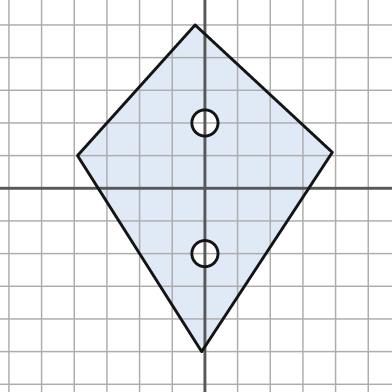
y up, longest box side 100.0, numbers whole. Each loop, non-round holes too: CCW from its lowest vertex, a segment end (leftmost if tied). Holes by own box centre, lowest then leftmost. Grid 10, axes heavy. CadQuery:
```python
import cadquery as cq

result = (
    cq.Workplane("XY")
    .moveTo(-1.0, -50.0)
    .lineTo(39.0, 11.0)
    .lineTo(-3.0, 50.0)
    .lineTo(-39.0, 10.0)
    .close()
    .moveTo(0.0, -20.0)
    .circle(4.0)
    .moveTo(0.0, 20.0)
    .circle(4.0)
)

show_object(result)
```